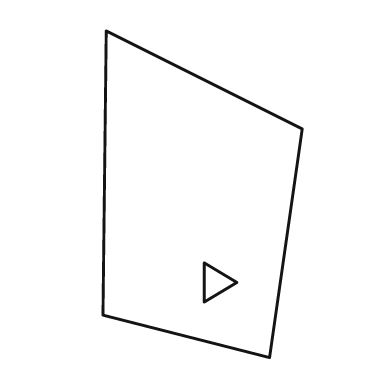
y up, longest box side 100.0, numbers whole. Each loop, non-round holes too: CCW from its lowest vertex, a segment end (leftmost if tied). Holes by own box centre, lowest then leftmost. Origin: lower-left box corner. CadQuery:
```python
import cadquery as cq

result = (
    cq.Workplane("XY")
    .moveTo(51.0, 0.0)
    .lineTo(61.0, 70.0)
    .lineTo(1.0, 100.0)
    .lineTo(0.0, 13.0)
    .close()
    .moveTo(31.0, 17.0)
    .lineTo(41.0, 23.0)
    .lineTo(31.0, 29.0)
    .close()
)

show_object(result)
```